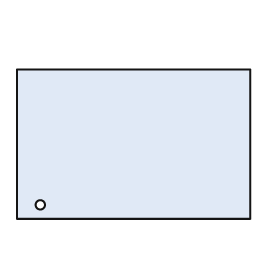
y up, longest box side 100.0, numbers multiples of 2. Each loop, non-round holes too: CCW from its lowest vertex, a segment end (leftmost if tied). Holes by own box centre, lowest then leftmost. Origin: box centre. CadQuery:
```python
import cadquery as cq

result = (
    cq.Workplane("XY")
    .moveTo(-50.0, -32.0)
    .lineTo(50.0, -32.0)
    .lineTo(50.0, 32.0)
    .lineTo(-50.0, 32.0)
    .close()
    .moveTo(-40.0, -26.0)
    .circle(2.0)
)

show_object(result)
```